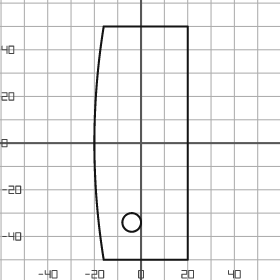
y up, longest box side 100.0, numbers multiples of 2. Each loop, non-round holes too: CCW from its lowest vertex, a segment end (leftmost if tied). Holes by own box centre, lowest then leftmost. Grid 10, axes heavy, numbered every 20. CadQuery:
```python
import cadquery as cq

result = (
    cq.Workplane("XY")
    .moveTo(-16.0, -50.0)
    .lineTo(20.0, -50.0)
    .lineTo(20.0, 50.0)
    .lineTo(-16.0, 50.0)
    .threePointArc((-20.0, 0.0), (-16.0, -50.0))
    .close()
    .moveTo(-4.0, -34.0)
    .circle(4.0)
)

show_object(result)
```